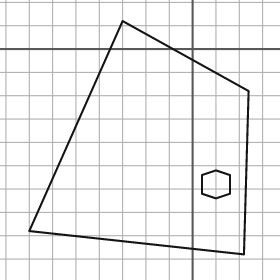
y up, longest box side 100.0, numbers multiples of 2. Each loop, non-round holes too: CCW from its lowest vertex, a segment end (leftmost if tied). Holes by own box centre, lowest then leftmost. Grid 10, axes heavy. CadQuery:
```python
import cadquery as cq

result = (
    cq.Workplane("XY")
    .moveTo(22.0, -88.0)
    .lineTo(24.0, -18.0)
    .lineTo(-30.0, 12.0)
    .lineTo(-70.0, -78.0)
    .close()
    .moveTo(10.0, -64.0)
    .lineTo(16.0, -62.0)
    .lineTo(16.0, -54.0)
    .lineTo(10.0, -52.0)
    .lineTo(4.0, -54.0)
    .lineTo(4.0, -62.0)
    .close()
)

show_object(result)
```